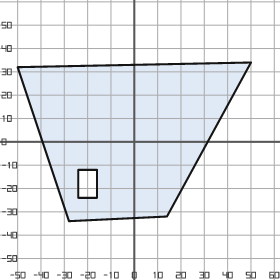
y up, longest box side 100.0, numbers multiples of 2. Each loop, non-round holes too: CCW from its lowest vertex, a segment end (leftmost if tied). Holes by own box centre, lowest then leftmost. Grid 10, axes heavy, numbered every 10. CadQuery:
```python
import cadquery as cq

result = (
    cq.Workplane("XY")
    .moveTo(-28.0, -34.0)
    .lineTo(14.0, -32.0)
    .lineTo(50.0, 34.0)
    .lineTo(-50.0, 32.0)
    .close()
    .moveTo(-24.0, -24.0)
    .lineTo(-16.0, -24.0)
    .lineTo(-16.0, -12.0)
    .lineTo(-24.0, -12.0)
    .close()
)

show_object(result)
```